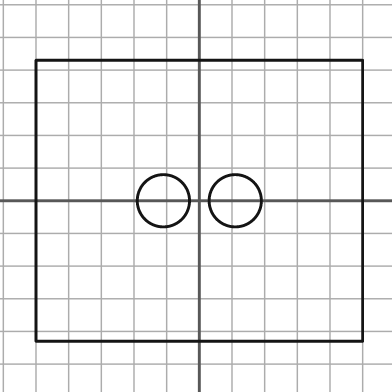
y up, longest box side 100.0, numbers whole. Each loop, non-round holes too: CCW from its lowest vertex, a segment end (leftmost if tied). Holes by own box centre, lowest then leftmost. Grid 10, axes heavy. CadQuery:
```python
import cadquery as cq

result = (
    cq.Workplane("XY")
    .moveTo(-50.0, -43.0)
    .lineTo(50.0, -43.0)
    .lineTo(50.0, 43.0)
    .lineTo(-50.0, 43.0)
    .close()
    .moveTo(-11.0, 0.0)
    .circle(8.0)
    .moveTo(11.0, 0.0)
    .circle(8.0)
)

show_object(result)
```